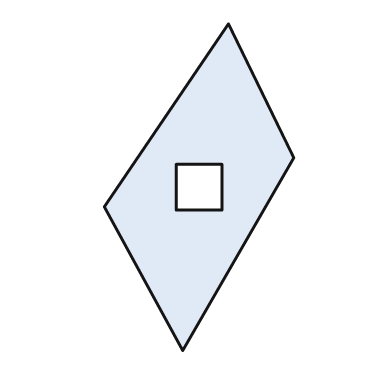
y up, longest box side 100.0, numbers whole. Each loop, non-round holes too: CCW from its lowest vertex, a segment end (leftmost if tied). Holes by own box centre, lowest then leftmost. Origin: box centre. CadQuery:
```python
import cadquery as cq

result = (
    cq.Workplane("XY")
    .moveTo(-5.0, -50.0)
    .lineTo(29.0, 9.0)
    .lineTo(9.0, 50.0)
    .lineTo(-29.0, -6.0)
    .close()
    .moveTo(-7.0, -7.0)
    .lineTo(7.0, -7.0)
    .lineTo(7.0, 7.0)
    .lineTo(-7.0, 7.0)
    .close()
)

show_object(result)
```